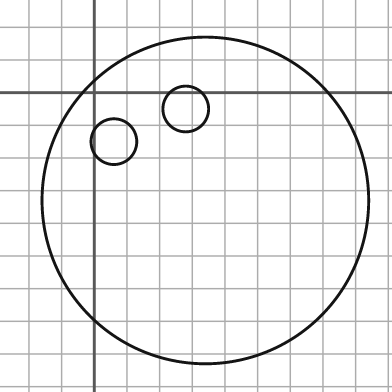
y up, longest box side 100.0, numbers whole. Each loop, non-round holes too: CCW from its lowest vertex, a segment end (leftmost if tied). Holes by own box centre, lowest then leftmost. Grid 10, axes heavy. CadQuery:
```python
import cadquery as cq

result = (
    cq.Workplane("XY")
    .moveTo(34.0, -33.0)
    .circle(50.0)
    .moveTo(6.0, -15.0)
    .circle(7.0)
    .moveTo(28.0, -5.0)
    .circle(7.0)
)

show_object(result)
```